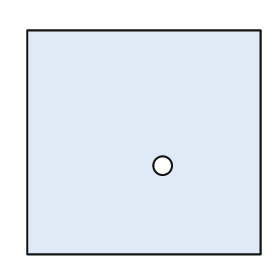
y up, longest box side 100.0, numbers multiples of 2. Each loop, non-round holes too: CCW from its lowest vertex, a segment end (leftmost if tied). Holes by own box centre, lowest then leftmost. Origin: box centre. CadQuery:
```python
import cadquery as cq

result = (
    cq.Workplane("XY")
    .moveTo(-50.0, -48.0)
    .lineTo(50.0, -48.0)
    .lineTo(50.0, 48.0)
    .lineTo(-50.0, 48.0)
    .close()
    .moveTo(8.0, -10.0)
    .circle(4.0)
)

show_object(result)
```